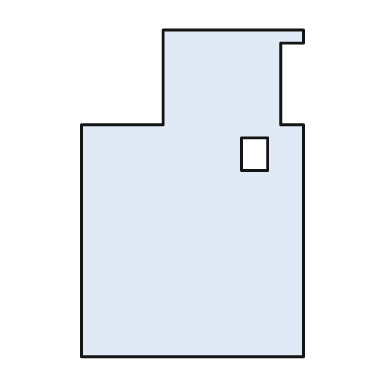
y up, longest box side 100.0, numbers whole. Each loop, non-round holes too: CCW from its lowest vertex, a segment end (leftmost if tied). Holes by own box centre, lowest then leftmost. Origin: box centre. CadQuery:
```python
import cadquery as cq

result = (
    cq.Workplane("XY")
    .moveTo(-34.0, -50.0)
    .lineTo(34.0, -50.0)
    .lineTo(34.0, 21.0)
    .lineTo(27.0, 21.0)
    .lineTo(27.0, 46.0)
    .lineTo(34.0, 46.0)
    .lineTo(34.0, 50.0)
    .lineTo(-9.0, 50.0)
    .lineTo(-9.0, 21.0)
    .lineTo(-34.0, 21.0)
    .close()
    .moveTo(15.0, 7.0)
    .lineTo(23.0, 7.0)
    .lineTo(23.0, 17.0)
    .lineTo(15.0, 17.0)
    .close()
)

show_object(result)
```